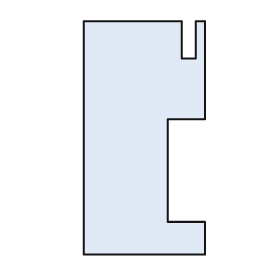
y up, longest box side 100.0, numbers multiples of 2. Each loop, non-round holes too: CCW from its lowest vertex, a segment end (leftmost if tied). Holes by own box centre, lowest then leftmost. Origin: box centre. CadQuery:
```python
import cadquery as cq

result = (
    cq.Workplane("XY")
    .moveTo(-26.0, -50.0)
    .lineTo(26.0, -50.0)
    .lineTo(26.0, -36.0)
    .lineTo(10.0, -36.0)
    .lineTo(10.0, 8.0)
    .lineTo(26.0, 8.0)
    .lineTo(26.0, 50.0)
    .lineTo(22.0, 50.0)
    .lineTo(22.0, 34.0)
    .lineTo(16.0, 34.0)
    .lineTo(16.0, 50.0)
    .lineTo(-26.0, 50.0)
    .close()
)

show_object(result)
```